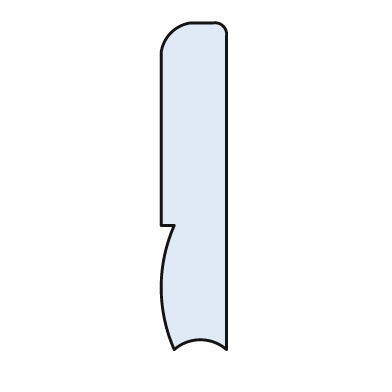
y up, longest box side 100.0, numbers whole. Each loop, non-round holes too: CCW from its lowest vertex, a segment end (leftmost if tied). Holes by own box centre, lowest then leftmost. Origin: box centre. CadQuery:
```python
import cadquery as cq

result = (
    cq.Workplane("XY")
    .moveTo(-6.0, -50.0)
    .threePointArc((2.0, -47.0), (10.0, -50.0))
    .lineTo(10.0, 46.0)
    .threePointArc((9.0, 49.0), (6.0, 50.0))
    .lineTo(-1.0, 50.0)
    .threePointArc((-7.0, 47.0), (-10.0, 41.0))
    .lineTo(-10.0, -12.0)
    .lineTo(-6.0, -12.0)
    .threePointArc((-10.0, -31.0), (-6.0, -50.0))
    .close()
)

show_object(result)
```